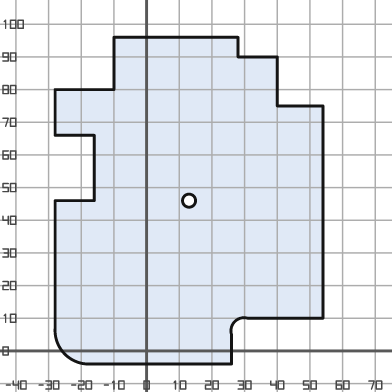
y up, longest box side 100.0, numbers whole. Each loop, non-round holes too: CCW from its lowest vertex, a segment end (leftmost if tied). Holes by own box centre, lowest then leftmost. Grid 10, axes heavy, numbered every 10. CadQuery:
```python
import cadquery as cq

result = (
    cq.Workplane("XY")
    .moveTo(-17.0, -4.0)
    .lineTo(26.0, -4.0)
    .lineTo(26.0, 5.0)
    .threePointArc((27.0, 9.0), (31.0, 10.0))
    .lineTo(54.0, 10.0)
    .lineTo(54.0, 75.0)
    .lineTo(40.0, 75.0)
    .lineTo(40.0, 90.0)
    .lineTo(28.0, 90.0)
    .lineTo(28.0, 96.0)
    .lineTo(-10.0, 96.0)
    .lineTo(-10.0, 80.0)
    .lineTo(-28.0, 80.0)
    .lineTo(-28.0, 66.0)
    .lineTo(-16.0, 66.0)
    .lineTo(-16.0, 46.0)
    .lineTo(-28.0, 46.0)
    .lineTo(-28.0, 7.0)
    .threePointArc((-25.0, -1.0), (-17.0, -4.0))
    .close()
    .moveTo(13.0, 46.0)
    .circle(2.0)
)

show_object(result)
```